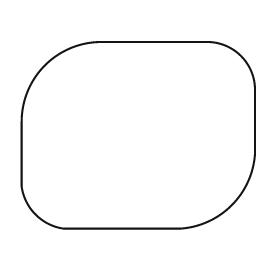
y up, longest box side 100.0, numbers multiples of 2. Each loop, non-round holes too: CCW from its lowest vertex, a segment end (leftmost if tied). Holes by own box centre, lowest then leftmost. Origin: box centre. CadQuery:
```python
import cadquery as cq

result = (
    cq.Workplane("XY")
    .moveTo(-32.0, -40.0)
    .lineTo(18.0, -40.0)
    .threePointArc((40.0, -30.0), (50.0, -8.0))
    .lineTo(50.0, 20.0)
    .threePointArc((44.0, 34.0), (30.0, 40.0))
    .lineTo(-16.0, 40.0)
    .threePointArc((-40.0, 30.0), (-50.0, 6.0))
    .lineTo(-50.0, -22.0)
    .threePointArc((-44.0, -34.0), (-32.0, -40.0))
    .close()
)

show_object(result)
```